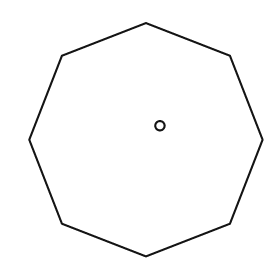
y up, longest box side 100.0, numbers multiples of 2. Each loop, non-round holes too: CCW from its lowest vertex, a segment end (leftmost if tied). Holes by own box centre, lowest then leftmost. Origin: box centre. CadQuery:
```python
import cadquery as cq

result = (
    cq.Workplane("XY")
    .moveTo(0.0, -50.0)
    .lineTo(36.0, -36.0)
    .lineTo(50.0, 0.0)
    .lineTo(36.0, 36.0)
    .lineTo(0.0, 50.0)
    .lineTo(-36.0, 36.0)
    .lineTo(-50.0, 0.0)
    .lineTo(-36.0, -36.0)
    .close()
    .moveTo(6.0, 6.0)
    .circle(2.0)
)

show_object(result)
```